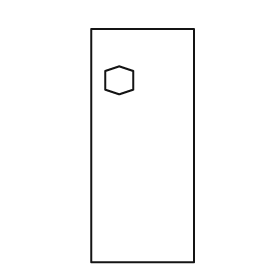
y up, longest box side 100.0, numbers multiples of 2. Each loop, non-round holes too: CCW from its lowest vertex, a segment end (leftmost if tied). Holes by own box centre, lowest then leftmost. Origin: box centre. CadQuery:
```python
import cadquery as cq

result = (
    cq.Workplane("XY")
    .moveTo(-22.0, -50.0)
    .lineTo(22.0, -50.0)
    .lineTo(22.0, 50.0)
    .lineTo(-22.0, 50.0)
    .close()
    .moveTo(-10.0, 22.0)
    .lineTo(-4.0, 24.0)
    .lineTo(-4.0, 32.0)
    .lineTo(-10.0, 34.0)
    .lineTo(-16.0, 32.0)
    .lineTo(-16.0, 24.0)
    .close()
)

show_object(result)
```